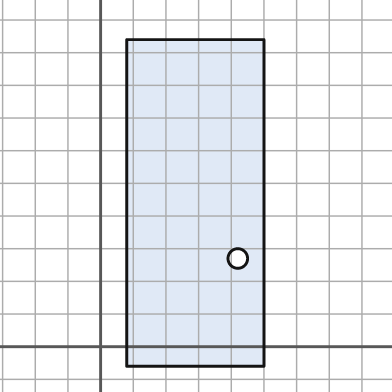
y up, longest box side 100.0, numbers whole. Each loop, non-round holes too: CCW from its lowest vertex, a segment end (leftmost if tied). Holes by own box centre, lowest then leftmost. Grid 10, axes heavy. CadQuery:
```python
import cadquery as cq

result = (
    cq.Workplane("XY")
    .moveTo(8.0, -6.0)
    .lineTo(50.0, -6.0)
    .lineTo(50.0, 94.0)
    .lineTo(8.0, 94.0)
    .close()
    .moveTo(42.0, 27.0)
    .circle(3.0)
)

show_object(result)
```